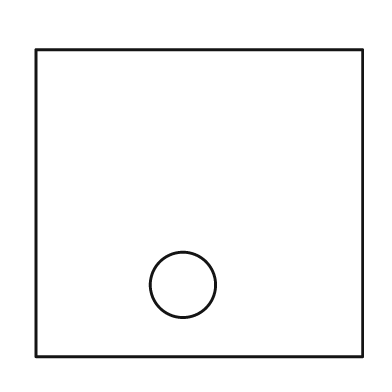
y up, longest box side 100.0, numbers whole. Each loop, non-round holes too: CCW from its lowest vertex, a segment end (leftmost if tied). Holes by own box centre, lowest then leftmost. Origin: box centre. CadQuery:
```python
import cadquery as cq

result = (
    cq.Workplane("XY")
    .moveTo(-50.0, -47.0)
    .lineTo(50.0, -47.0)
    .lineTo(50.0, 47.0)
    .lineTo(-50.0, 47.0)
    .close()
    .moveTo(-5.0, -25.0)
    .circle(10.0)
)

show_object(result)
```